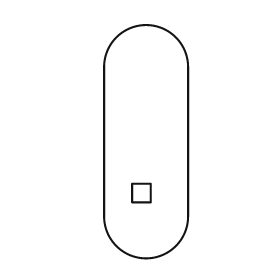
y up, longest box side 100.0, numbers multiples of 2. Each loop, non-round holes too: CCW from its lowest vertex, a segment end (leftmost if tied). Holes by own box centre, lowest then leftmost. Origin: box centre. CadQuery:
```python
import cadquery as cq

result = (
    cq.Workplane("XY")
    .moveTo(-18.0, -32.0)
    .threePointArc((0.0, -50.0), (18.0, -32.0))
    .lineTo(18.0, 32.0)
    .threePointArc((0.0, 50.0), (-18.0, 32.0))
    .close()
    .moveTo(-6.0, -26.0)
    .lineTo(2.0, -26.0)
    .lineTo(2.0, -18.0)
    .lineTo(-6.0, -18.0)
    .close()
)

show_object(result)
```